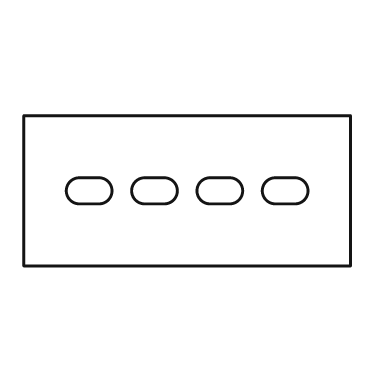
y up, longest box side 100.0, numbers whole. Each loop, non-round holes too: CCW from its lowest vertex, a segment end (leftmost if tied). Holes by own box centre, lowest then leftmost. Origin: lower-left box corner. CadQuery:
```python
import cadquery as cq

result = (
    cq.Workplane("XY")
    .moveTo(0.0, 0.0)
    .lineTo(100.0, 0.0)
    .lineTo(100.0, 46.0)
    .lineTo(0.0, 46.0)
    .close()
    .moveTo(17.0, 19.0)
    .lineTo(23.0, 19.0)
    .threePointArc((27.0, 23.0), (23.0, 27.0))
    .lineTo(17.0, 27.0)
    .threePointArc((13.0, 23.0), (17.0, 19.0))
    .close()
    .moveTo(37.0, 19.0)
    .lineTo(43.0, 19.0)
    .threePointArc((47.0, 23.0), (43.0, 27.0))
    .lineTo(37.0, 27.0)
    .threePointArc((33.0, 23.0), (37.0, 19.0))
    .close()
    .moveTo(57.0, 19.0)
    .lineTo(63.0, 19.0)
    .threePointArc((67.0, 23.0), (63.0, 27.0))
    .lineTo(57.0, 27.0)
    .threePointArc((53.0, 23.0), (57.0, 19.0))
    .close()
    .moveTo(77.0, 19.0)
    .lineTo(83.0, 19.0)
    .threePointArc((87.0, 23.0), (83.0, 27.0))
    .lineTo(77.0, 27.0)
    .threePointArc((73.0, 23.0), (77.0, 19.0))
    .close()
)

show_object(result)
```